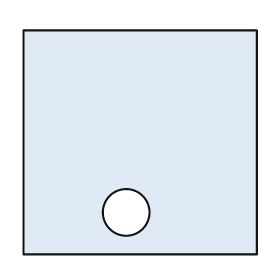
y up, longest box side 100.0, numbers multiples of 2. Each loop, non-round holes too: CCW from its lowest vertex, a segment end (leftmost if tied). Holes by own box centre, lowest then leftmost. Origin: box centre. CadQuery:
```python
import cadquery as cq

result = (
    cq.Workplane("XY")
    .moveTo(-50.0, -48.0)
    .lineTo(50.0, -48.0)
    .lineTo(50.0, 48.0)
    .lineTo(-50.0, 48.0)
    .close()
    .moveTo(-6.0, -30.0)
    .circle(10.0)
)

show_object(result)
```